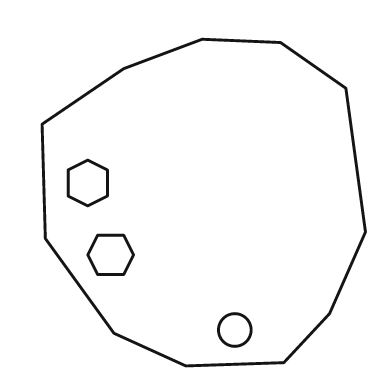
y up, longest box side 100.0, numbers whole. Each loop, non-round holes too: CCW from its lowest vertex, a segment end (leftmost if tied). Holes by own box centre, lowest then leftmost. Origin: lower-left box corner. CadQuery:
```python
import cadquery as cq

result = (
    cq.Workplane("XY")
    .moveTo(44.0, 0.0)
    .lineTo(74.0, 1.0)
    .lineTo(88.0, 16.0)
    .lineTo(99.0, 41.0)
    .lineTo(93.0, 85.0)
    .lineTo(73.0, 99.0)
    .lineTo(49.0, 100.0)
    .lineTo(25.0, 91.0)
    .lineTo(0.0, 74.0)
    .lineTo(1.0, 39.0)
    .lineTo(22.0, 10.0)
    .close()
    .moveTo(59.0, 11.0)
    .circle(5.0)
    .moveTo(17.0, 28.0)
    .lineTo(25.0, 28.0)
    .lineTo(28.0, 34.0)
    .lineTo(25.0, 40.0)
    .lineTo(17.0, 40.0)
    .lineTo(14.0, 34.0)
    .close()
    .moveTo(14.0, 49.0)
    .lineTo(20.0, 52.0)
    .lineTo(20.0, 60.0)
    .lineTo(14.0, 63.0)
    .lineTo(8.0, 60.0)
    .lineTo(8.0, 52.0)
    .close()
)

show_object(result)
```